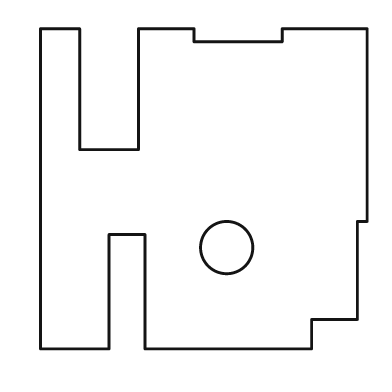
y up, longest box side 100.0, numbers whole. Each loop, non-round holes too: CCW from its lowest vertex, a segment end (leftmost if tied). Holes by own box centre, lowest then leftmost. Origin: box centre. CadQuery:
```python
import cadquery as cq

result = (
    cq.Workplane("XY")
    .moveTo(-50.0, -49.0)
    .lineTo(-29.0, -49.0)
    .lineTo(-29.0, -14.0)
    .lineTo(-18.0, -14.0)
    .lineTo(-18.0, -49.0)
    .lineTo(33.0, -49.0)
    .lineTo(33.0, -40.0)
    .lineTo(47.0, -40.0)
    .lineTo(47.0, -10.0)
    .lineTo(50.0, -10.0)
    .lineTo(50.0, 49.0)
    .lineTo(24.0, 49.0)
    .lineTo(24.0, 45.0)
    .lineTo(-3.0, 45.0)
    .lineTo(-3.0, 49.0)
    .lineTo(-20.0, 49.0)
    .lineTo(-20.0, 12.0)
    .lineTo(-38.0, 12.0)
    .lineTo(-38.0, 49.0)
    .lineTo(-50.0, 49.0)
    .close()
    .moveTo(7.0, -18.0)
    .circle(8.0)
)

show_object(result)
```